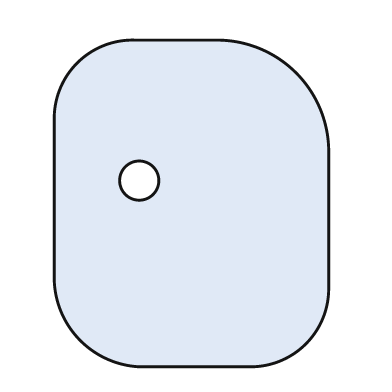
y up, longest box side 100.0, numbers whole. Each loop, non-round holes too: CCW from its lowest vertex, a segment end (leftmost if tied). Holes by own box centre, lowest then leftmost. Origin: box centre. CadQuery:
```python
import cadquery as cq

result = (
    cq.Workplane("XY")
    .moveTo(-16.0, -50.0)
    .lineTo(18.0, -50.0)
    .threePointArc((35.0, -43.0), (42.0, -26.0))
    .lineTo(42.0, 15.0)
    .threePointArc((32.0, 40.0), (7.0, 50.0))
    .lineTo(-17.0, 50.0)
    .threePointArc((-35.0, 43.0), (-42.0, 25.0))
    .lineTo(-42.0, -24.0)
    .threePointArc((-34.0, -42.0), (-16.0, -50.0))
    .close()
    .moveTo(-16.0, 7.0)
    .circle(6.0)
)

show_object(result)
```